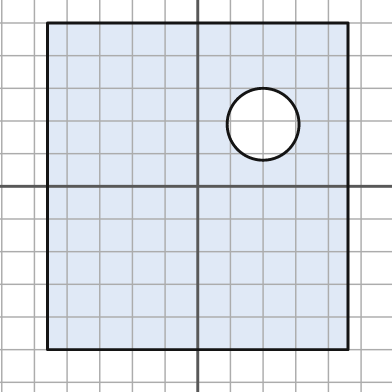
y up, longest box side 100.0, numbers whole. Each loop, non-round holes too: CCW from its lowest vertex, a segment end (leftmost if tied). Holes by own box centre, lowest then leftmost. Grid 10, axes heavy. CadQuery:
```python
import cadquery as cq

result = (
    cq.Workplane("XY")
    .moveTo(-46.0, -50.0)
    .lineTo(46.0, -50.0)
    .lineTo(46.0, 50.0)
    .lineTo(-46.0, 50.0)
    .close()
    .moveTo(20.0, 19.0)
    .circle(11.0)
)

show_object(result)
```